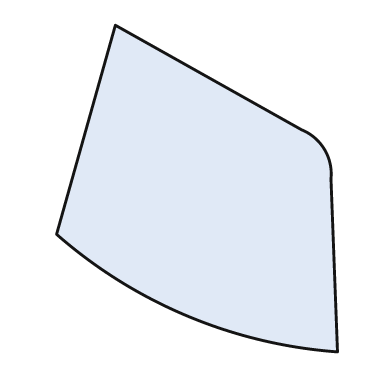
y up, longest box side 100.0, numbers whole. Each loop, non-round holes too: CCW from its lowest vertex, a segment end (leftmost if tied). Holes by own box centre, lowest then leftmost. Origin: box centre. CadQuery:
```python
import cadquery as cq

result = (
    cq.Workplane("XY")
    .moveTo(43.0, -50.0)
    .lineTo(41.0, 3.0)
    .threePointArc((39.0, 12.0), (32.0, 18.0))
    .lineTo(-25.0, 50.0)
    .lineTo(-43.0, -14.0)
    .threePointArc((-3.0, -39.0), (43.0, -50.0))
    .close()
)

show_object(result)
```